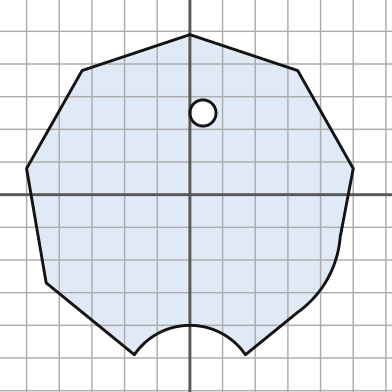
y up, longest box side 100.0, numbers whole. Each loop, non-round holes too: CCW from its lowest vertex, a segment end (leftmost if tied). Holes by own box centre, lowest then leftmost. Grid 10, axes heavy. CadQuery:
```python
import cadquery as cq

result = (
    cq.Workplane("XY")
    .moveTo(-17.0, -49.0)
    .threePointArc((0.0, -40.0), (17.0, -49.0))
    .lineTo(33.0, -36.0)
    .threePointArc((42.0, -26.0), (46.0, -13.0))
    .lineTo(50.0, 8.0)
    .lineTo(33.0, 38.0)
    .lineTo(0.0, 49.0)
    .lineTo(-33.0, 38.0)
    .lineTo(-50.0, 8.0)
    .lineTo(-44.0, -27.0)
    .close()
    .moveTo(4.0, 25.0)
    .circle(4.0)
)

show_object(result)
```